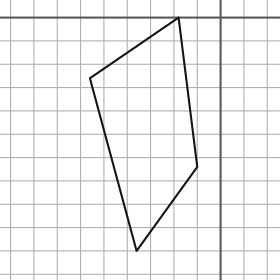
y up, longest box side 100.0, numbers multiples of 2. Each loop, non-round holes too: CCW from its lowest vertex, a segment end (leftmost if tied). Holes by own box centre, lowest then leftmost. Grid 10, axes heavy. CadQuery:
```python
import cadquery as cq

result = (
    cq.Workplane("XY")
    .moveTo(-36.0, -100.0)
    .lineTo(-10.0, -64.0)
    .lineTo(-18.0, 0.0)
    .lineTo(-56.0, -26.0)
    .close()
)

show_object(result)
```